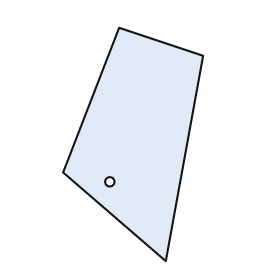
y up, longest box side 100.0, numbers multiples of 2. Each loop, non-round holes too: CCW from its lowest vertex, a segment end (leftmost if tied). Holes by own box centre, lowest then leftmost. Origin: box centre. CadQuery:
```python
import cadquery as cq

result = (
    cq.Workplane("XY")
    .moveTo(14.0, -50.0)
    .lineTo(30.0, 38.0)
    .lineTo(-6.0, 50.0)
    .lineTo(-30.0, -12.0)
    .close()
    .moveTo(-10.0, -16.0)
    .circle(2.0)
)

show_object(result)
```